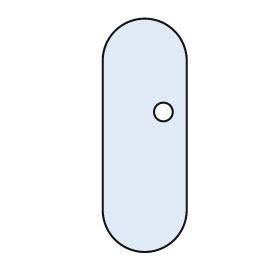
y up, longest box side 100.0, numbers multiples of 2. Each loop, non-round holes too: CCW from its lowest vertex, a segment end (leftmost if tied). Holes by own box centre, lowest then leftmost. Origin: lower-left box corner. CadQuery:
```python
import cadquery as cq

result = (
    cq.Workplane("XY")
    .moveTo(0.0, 18.0)
    .threePointArc((18.0, 0.0), (36.0, 18.0))
    .lineTo(36.0, 82.0)
    .threePointArc((18.0, 100.0), (0.0, 82.0))
    .close()
    .moveTo(26.0, 60.0)
    .circle(4.0)
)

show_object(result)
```